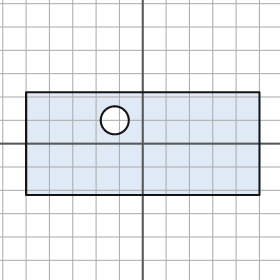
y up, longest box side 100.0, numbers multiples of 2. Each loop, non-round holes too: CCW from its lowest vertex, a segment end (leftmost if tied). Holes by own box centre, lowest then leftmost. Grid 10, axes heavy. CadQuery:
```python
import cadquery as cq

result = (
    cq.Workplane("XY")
    .moveTo(-50.0, -22.0)
    .lineTo(50.0, -22.0)
    .lineTo(50.0, 22.0)
    .lineTo(-50.0, 22.0)
    .close()
    .moveTo(-12.0, 10.0)
    .circle(6.0)
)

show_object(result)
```